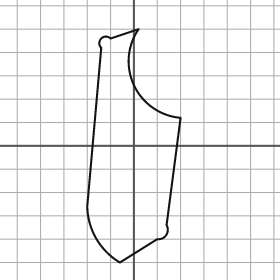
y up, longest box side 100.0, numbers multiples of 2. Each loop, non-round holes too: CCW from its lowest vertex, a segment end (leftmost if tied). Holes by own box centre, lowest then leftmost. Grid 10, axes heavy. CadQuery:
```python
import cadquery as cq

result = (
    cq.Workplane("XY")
    .moveTo(-6.0, -50.0)
    .lineTo(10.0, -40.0)
    .threePointArc((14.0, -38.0), (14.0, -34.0))
    .lineTo(20.0, 12.0)
    .threePointArc((0.0, 26.0), (2.0, 50.0))
    .lineTo(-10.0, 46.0)
    .threePointArc((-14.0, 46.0), (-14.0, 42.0))
    .lineTo(-20.0, -26.0)
    .threePointArc((-16.0, -40.0), (-6.0, -50.0))
    .close()
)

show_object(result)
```